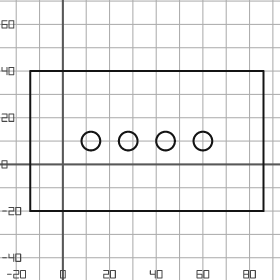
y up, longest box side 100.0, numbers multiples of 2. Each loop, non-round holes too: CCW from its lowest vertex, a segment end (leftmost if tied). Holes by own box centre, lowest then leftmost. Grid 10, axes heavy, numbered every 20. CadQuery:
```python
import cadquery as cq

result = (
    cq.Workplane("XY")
    .moveTo(-14.0, -20.0)
    .lineTo(86.0, -20.0)
    .lineTo(86.0, 40.0)
    .lineTo(-14.0, 40.0)
    .close()
    .moveTo(12.0, 10.0)
    .circle(4.0)
    .moveTo(28.0, 10.0)
    .circle(4.0)
    .moveTo(44.0, 10.0)
    .circle(4.0)
    .moveTo(60.0, 10.0)
    .circle(4.0)
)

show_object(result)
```